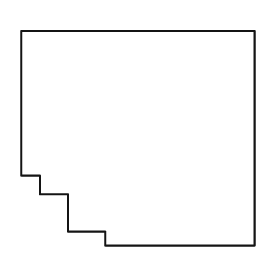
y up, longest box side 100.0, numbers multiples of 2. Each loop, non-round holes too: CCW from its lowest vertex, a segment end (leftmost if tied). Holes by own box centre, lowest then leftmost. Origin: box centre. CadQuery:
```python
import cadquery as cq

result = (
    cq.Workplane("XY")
    .moveTo(-14.0, -46.0)
    .lineTo(50.0, -46.0)
    .lineTo(50.0, 46.0)
    .lineTo(-50.0, 46.0)
    .lineTo(-50.0, -16.0)
    .lineTo(-42.0, -16.0)
    .lineTo(-42.0, -24.0)
    .lineTo(-30.0, -24.0)
    .lineTo(-30.0, -40.0)
    .lineTo(-14.0, -40.0)
    .close()
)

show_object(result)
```